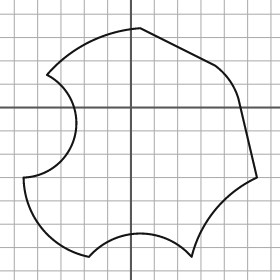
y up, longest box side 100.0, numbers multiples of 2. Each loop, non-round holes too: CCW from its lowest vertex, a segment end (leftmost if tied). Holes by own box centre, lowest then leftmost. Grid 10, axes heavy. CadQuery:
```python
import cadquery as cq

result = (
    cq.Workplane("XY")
    .moveTo(-18.0, -64.0)
    .threePointArc((4.0, -54.0), (26.0, -64.0))
    .threePointArc((36.0, -44.0), (54.0, -30.0))
    .lineTo(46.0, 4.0)
    .threePointArc((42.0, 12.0), (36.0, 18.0))
    .lineTo(4.0, 34.0)
    .threePointArc((-18.0, 28.0), (-36.0, 14.0))
    .threePointArc((-24.0, -12.0), (-46.0, -30.0))
    .threePointArc((-38.0, -52.0), (-18.0, -64.0))
    .close()
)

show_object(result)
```